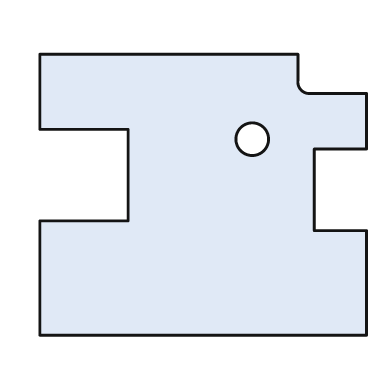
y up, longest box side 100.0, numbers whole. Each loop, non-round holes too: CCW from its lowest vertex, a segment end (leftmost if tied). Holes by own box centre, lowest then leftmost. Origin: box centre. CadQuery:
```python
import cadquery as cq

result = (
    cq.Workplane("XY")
    .moveTo(-50.0, -43.0)
    .lineTo(50.0, -43.0)
    .lineTo(50.0, -11.0)
    .lineTo(34.0, -11.0)
    .lineTo(34.0, 14.0)
    .lineTo(50.0, 14.0)
    .lineTo(50.0, 31.0)
    .lineTo(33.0, 31.0)
    .threePointArc((30.0, 32.0), (29.0, 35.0))
    .lineTo(29.0, 43.0)
    .lineTo(-50.0, 43.0)
    .lineTo(-50.0, 20.0)
    .lineTo(-23.0, 20.0)
    .lineTo(-23.0, -8.0)
    .lineTo(-50.0, -8.0)
    .close()
    .moveTo(15.0, 17.0)
    .circle(5.0)
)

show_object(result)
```